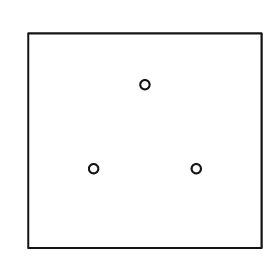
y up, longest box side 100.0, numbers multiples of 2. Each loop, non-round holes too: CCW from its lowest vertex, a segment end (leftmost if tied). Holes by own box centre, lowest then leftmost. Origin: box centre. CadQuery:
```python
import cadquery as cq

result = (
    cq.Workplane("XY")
    .moveTo(-50.0, -46.0)
    .lineTo(50.0, -46.0)
    .lineTo(50.0, 46.0)
    .lineTo(-50.0, 46.0)
    .close()
    .moveTo(-22.0, -12.0)
    .circle(2.0)
    .moveTo(22.0, -12.0)
    .circle(2.0)
    .moveTo(0.0, 24.0)
    .circle(2.0)
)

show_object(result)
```